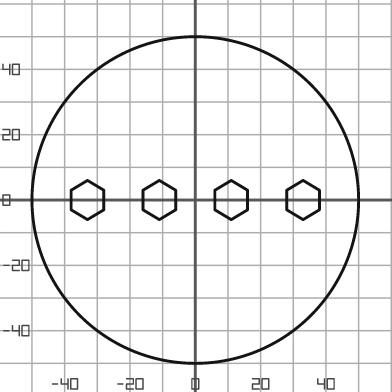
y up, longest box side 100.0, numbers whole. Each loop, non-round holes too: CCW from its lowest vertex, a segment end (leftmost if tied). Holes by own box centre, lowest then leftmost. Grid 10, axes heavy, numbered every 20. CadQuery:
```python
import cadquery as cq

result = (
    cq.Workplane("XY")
    .moveTo(0.0, 0.0)
    .circle(50.0)
    .moveTo(-33.0, -6.0)
    .lineTo(-28.0, -3.0)
    .lineTo(-28.0, 3.0)
    .lineTo(-33.0, 6.0)
    .lineTo(-38.0, 3.0)
    .lineTo(-38.0, -3.0)
    .close()
    .moveTo(-11.0, -6.0)
    .lineTo(-6.0, -3.0)
    .lineTo(-6.0, 3.0)
    .lineTo(-11.0, 6.0)
    .lineTo(-16.0, 3.0)
    .lineTo(-16.0, -3.0)
    .close()
    .moveTo(11.0, -6.0)
    .lineTo(16.0, -3.0)
    .lineTo(16.0, 3.0)
    .lineTo(11.0, 6.0)
    .lineTo(6.0, 3.0)
    .lineTo(6.0, -3.0)
    .close()
    .moveTo(33.0, -6.0)
    .lineTo(38.0, -3.0)
    .lineTo(38.0, 3.0)
    .lineTo(33.0, 6.0)
    .lineTo(28.0, 3.0)
    .lineTo(28.0, -3.0)
    .close()
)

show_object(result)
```